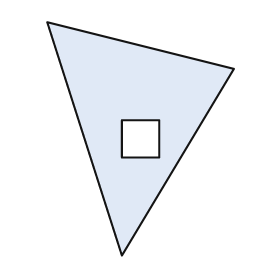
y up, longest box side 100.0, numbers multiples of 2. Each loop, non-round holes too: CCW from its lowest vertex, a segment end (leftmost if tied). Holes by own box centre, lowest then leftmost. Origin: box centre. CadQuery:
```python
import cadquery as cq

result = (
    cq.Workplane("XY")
    .moveTo(-8.0, -50.0)
    .lineTo(40.0, 30.0)
    .lineTo(-40.0, 50.0)
    .close()
    .moveTo(-8.0, -8.0)
    .lineTo(8.0, -8.0)
    .lineTo(8.0, 8.0)
    .lineTo(-8.0, 8.0)
    .close()
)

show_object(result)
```